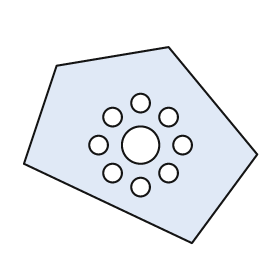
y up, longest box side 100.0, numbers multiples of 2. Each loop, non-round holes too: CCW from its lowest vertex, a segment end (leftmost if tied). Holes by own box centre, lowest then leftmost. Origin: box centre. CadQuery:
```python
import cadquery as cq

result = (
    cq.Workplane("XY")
    .moveTo(22.0, -42.0)
    .lineTo(50.0, -4.0)
    .lineTo(12.0, 42.0)
    .lineTo(-36.0, 34.0)
    .lineTo(-50.0, -8.0)
    .close()
    .moveTo(0.0, -18.0)
    .circle(4.0)
    .moveTo(-12.0, -12.0)
    .circle(4.0)
    .moveTo(12.0, -12.0)
    .circle(4.0)
    .moveTo(-18.0, 0.0)
    .circle(4.0)
    .moveTo(0.0, 0.0)
    .circle(8.0)
    .moveTo(18.0, 0.0)
    .circle(4.0)
    .moveTo(-12.0, 12.0)
    .circle(4.0)
    .moveTo(12.0, 12.0)
    .circle(4.0)
    .moveTo(0.0, 18.0)
    .circle(4.0)
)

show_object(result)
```